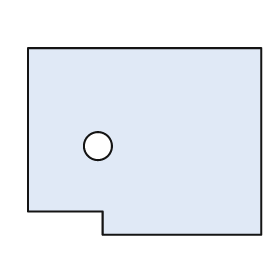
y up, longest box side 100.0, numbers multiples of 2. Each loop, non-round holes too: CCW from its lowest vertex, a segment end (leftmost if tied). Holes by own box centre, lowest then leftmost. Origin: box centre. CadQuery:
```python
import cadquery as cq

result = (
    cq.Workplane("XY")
    .moveTo(-18.0, -40.0)
    .lineTo(50.0, -40.0)
    .lineTo(50.0, 40.0)
    .lineTo(-50.0, 40.0)
    .lineTo(-50.0, -30.0)
    .lineTo(-18.0, -30.0)
    .close()
    .moveTo(-20.0, -2.0)
    .circle(6.0)
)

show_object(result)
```